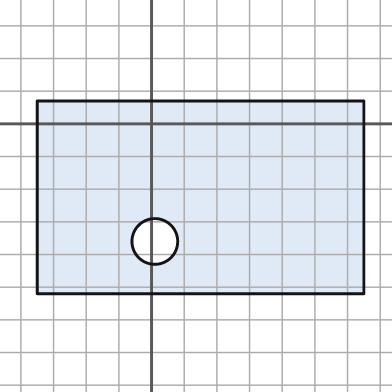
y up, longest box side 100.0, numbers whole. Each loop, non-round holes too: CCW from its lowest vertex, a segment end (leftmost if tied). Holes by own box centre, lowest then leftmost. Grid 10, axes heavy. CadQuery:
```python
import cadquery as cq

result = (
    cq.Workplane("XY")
    .moveTo(-35.0, -52.0)
    .lineTo(65.0, -52.0)
    .lineTo(65.0, 7.0)
    .lineTo(-35.0, 7.0)
    .close()
    .moveTo(1.0, -36.0)
    .circle(7.0)
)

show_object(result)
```